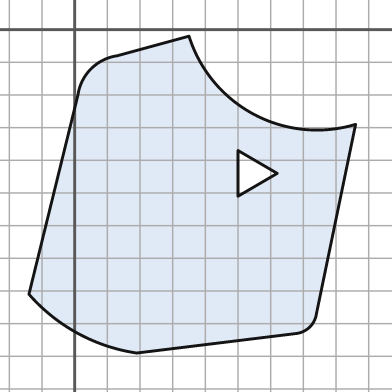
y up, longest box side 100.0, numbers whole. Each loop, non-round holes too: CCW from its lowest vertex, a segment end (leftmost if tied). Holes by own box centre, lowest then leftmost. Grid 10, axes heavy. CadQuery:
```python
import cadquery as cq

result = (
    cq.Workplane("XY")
    .moveTo(19.0, -99.0)
    .lineTo(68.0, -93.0)
    .threePointArc((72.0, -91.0), (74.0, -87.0))
    .lineTo(86.0, -29.0)
    .threePointArc((55.0, -26.0), (35.0, -2.0))
    .lineTo(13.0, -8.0)
    .threePointArc((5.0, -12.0), (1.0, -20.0))
    .lineTo(-14.0, -81.0)
    .threePointArc((1.0, -93.0), (19.0, -99.0))
    .close()
    .moveTo(50.0, -51.0)
    .lineTo(62.0, -44.0)
    .lineTo(50.0, -37.0)
    .close()
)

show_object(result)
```